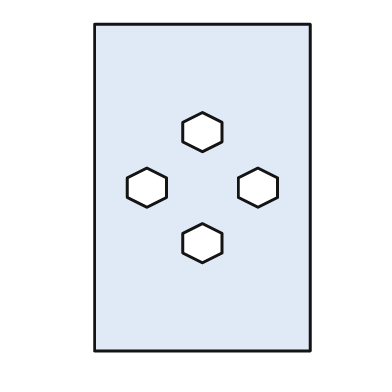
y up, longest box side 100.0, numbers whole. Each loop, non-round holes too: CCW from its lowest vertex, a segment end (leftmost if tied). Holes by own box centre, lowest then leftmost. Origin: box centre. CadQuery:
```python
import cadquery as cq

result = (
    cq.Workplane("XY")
    .moveTo(-33.0, -50.0)
    .lineTo(33.0, -50.0)
    .lineTo(33.0, 50.0)
    .lineTo(-33.0, 50.0)
    .close()
    .moveTo(0.0, -23.0)
    .lineTo(6.0, -20.0)
    .lineTo(6.0, -14.0)
    .lineTo(0.0, -11.0)
    .lineTo(-6.0, -14.0)
    .lineTo(-6.0, -20.0)
    .close()
    .moveTo(-17.0, -6.0)
    .lineTo(-11.0, -3.0)
    .lineTo(-11.0, 3.0)
    .lineTo(-17.0, 6.0)
    .lineTo(-23.0, 3.0)
    .lineTo(-23.0, -3.0)
    .close()
    .moveTo(17.0, -6.0)
    .lineTo(23.0, -3.0)
    .lineTo(23.0, 3.0)
    .lineTo(17.0, 6.0)
    .lineTo(11.0, 3.0)
    .lineTo(11.0, -3.0)
    .close()
    .moveTo(0.0, 11.0)
    .lineTo(6.0, 14.0)
    .lineTo(6.0, 20.0)
    .lineTo(0.0, 23.0)
    .lineTo(-6.0, 20.0)
    .lineTo(-6.0, 14.0)
    .close()
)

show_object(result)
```